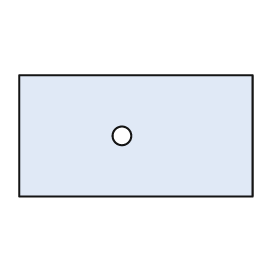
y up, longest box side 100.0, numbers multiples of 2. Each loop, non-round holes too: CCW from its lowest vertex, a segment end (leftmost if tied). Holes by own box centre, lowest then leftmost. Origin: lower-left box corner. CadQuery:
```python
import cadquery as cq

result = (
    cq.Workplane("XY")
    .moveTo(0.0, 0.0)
    .lineTo(100.0, 0.0)
    .lineTo(100.0, 52.0)
    .lineTo(0.0, 52.0)
    .close()
    .moveTo(44.0, 26.0)
    .circle(4.0)
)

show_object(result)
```